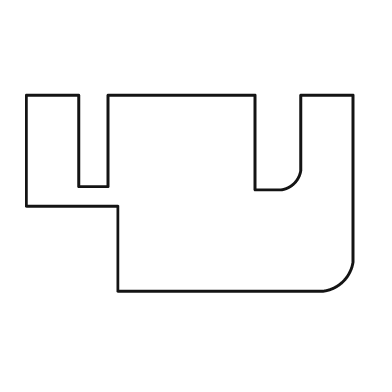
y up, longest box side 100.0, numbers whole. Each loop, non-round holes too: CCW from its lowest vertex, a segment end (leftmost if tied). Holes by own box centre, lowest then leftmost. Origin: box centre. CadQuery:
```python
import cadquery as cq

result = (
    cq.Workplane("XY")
    .moveTo(-22.0, -30.0)
    .lineTo(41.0, -30.0)
    .threePointArc((47.0, -27.0), (50.0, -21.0))
    .lineTo(50.0, 30.0)
    .lineTo(34.0, 30.0)
    .lineTo(34.0, 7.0)
    .threePointArc((32.0, 3.0), (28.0, 1.0))
    .lineTo(20.0, 1.0)
    .lineTo(20.0, 30.0)
    .lineTo(-25.0, 30.0)
    .lineTo(-25.0, 2.0)
    .lineTo(-34.0, 2.0)
    .lineTo(-34.0, 30.0)
    .lineTo(-50.0, 30.0)
    .lineTo(-50.0, -4.0)
    .lineTo(-22.0, -4.0)
    .close()
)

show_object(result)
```